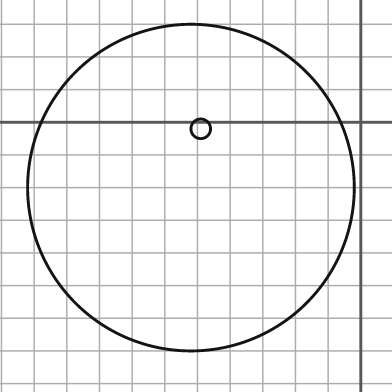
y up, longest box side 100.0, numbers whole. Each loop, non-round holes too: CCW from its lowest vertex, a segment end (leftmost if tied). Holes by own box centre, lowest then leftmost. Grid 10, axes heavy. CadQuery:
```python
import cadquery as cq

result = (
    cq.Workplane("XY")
    .moveTo(-52.0, -20.0)
    .circle(50.0)
    .moveTo(-49.0, -2.0)
    .circle(3.0)
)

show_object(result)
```